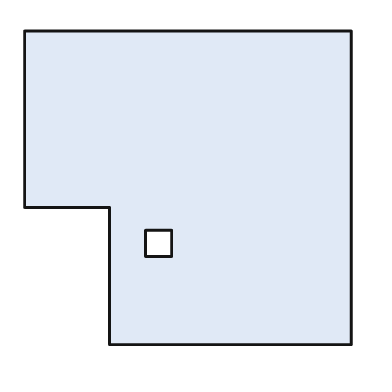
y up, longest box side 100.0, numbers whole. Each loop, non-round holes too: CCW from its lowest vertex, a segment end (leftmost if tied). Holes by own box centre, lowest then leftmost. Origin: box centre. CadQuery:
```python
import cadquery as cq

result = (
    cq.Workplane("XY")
    .moveTo(-24.0, -48.0)
    .lineTo(50.0, -48.0)
    .lineTo(50.0, 48.0)
    .lineTo(-50.0, 48.0)
    .lineTo(-50.0, -6.0)
    .lineTo(-24.0, -6.0)
    .close()
    .moveTo(-13.0, -21.0)
    .lineTo(-5.0, -21.0)
    .lineTo(-5.0, -13.0)
    .lineTo(-13.0, -13.0)
    .close()
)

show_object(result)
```